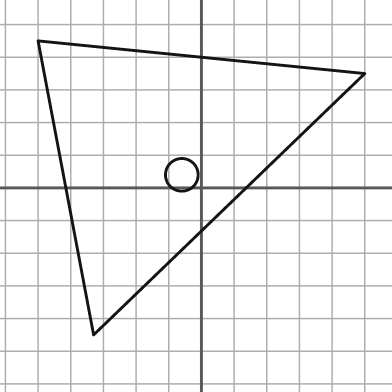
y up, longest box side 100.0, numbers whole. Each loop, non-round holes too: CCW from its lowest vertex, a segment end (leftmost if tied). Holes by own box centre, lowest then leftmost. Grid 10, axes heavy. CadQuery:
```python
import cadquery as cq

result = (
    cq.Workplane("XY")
    .moveTo(-33.0, -45.0)
    .lineTo(50.0, 35.0)
    .lineTo(-50.0, 45.0)
    .close()
    .moveTo(-6.0, 4.0)
    .circle(5.0)
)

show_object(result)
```